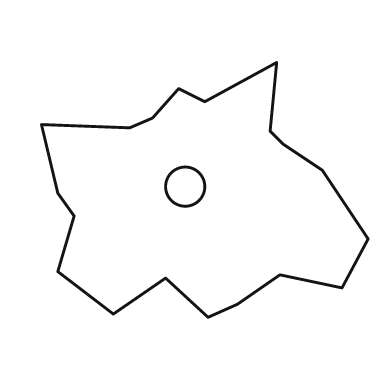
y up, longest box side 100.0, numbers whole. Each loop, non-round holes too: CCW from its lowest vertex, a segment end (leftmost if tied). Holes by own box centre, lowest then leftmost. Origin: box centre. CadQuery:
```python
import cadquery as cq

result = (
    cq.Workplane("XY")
    .moveTo(1.0, -39.0)
    .lineTo(10.0, -35.0)
    .lineTo(23.0, -26.0)
    .lineTo(42.0, -30.0)
    .lineTo(50.0, -15.0)
    .lineTo(36.0, 6.0)
    .lineTo(24.0, 14.0)
    .lineTo(20.0, 18.0)
    .lineTo(22.0, 39.0)
    .lineTo(0.0, 27.0)
    .lineTo(-8.0, 31.0)
    .lineTo(-16.0, 22.0)
    .lineTo(-23.0, 19.0)
    .lineTo(-50.0, 20.0)
    .lineTo(-45.0, -1.0)
    .lineTo(-40.0, -8.0)
    .lineTo(-45.0, -25.0)
    .lineTo(-28.0, -38.0)
    .lineTo(-12.0, -27.0)
    .close()
    .moveTo(-6.0, 1.0)
    .circle(6.0)
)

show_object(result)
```